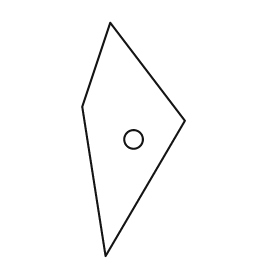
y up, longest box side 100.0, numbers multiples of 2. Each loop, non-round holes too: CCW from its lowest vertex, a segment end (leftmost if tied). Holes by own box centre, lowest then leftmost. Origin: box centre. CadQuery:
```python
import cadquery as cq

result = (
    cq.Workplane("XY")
    .moveTo(-12.0, -50.0)
    .lineTo(22.0, 8.0)
    .lineTo(-10.0, 50.0)
    .lineTo(-22.0, 14.0)
    .close()
    .moveTo(0.0, 0.0)
    .circle(4.0)
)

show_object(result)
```